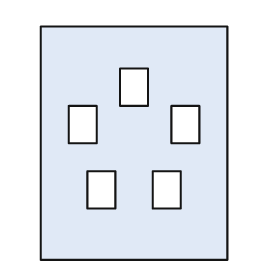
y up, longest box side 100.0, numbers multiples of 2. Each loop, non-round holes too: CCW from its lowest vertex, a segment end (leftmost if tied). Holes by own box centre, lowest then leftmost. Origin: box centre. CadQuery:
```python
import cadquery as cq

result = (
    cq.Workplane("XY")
    .moveTo(-40.0, -50.0)
    .lineTo(40.0, -50.0)
    .lineTo(40.0, 50.0)
    .lineTo(-40.0, 50.0)
    .close()
    .moveTo(-20.0, -28.0)
    .lineTo(-8.0, -28.0)
    .lineTo(-8.0, -12.0)
    .lineTo(-20.0, -12.0)
    .close()
    .moveTo(8.0, -28.0)
    .lineTo(20.0, -28.0)
    .lineTo(20.0, -12.0)
    .lineTo(8.0, -12.0)
    .close()
    .moveTo(-28.0, 0.0)
    .lineTo(-16.0, 0.0)
    .lineTo(-16.0, 16.0)
    .lineTo(-28.0, 16.0)
    .close()
    .moveTo(16.0, 0.0)
    .lineTo(28.0, 0.0)
    .lineTo(28.0, 16.0)
    .lineTo(16.0, 16.0)
    .close()
    .moveTo(-6.0, 16.0)
    .lineTo(6.0, 16.0)
    .lineTo(6.0, 32.0)
    .lineTo(-6.0, 32.0)
    .close()
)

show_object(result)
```